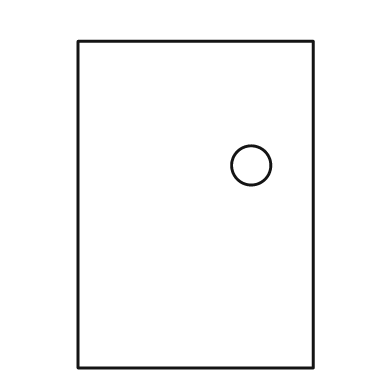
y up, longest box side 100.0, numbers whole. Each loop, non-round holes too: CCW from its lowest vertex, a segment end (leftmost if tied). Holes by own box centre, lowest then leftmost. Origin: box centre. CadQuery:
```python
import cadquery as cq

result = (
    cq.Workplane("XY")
    .moveTo(-36.0, -50.0)
    .lineTo(36.0, -50.0)
    .lineTo(36.0, 50.0)
    .lineTo(-36.0, 50.0)
    .close()
    .moveTo(17.0, 12.0)
    .circle(6.0)
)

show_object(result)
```